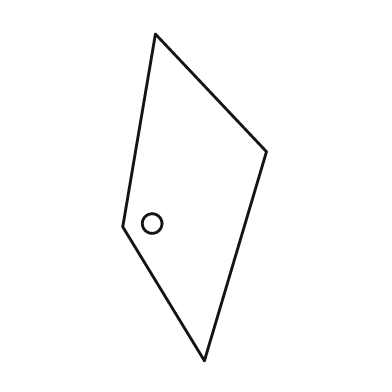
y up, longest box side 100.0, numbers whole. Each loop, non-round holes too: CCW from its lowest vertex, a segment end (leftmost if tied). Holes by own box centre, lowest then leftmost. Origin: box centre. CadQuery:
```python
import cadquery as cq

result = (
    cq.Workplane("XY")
    .moveTo(3.0, -50.0)
    .lineTo(22.0, 14.0)
    .lineTo(-12.0, 50.0)
    .lineTo(-22.0, -9.0)
    .close()
    .moveTo(-13.0, -8.0)
    .circle(3.0)
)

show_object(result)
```